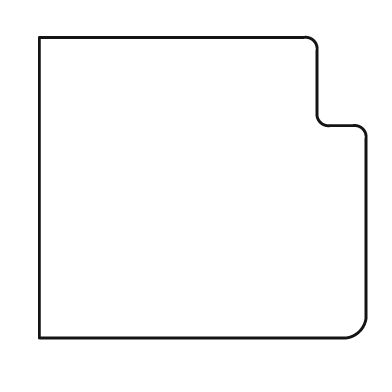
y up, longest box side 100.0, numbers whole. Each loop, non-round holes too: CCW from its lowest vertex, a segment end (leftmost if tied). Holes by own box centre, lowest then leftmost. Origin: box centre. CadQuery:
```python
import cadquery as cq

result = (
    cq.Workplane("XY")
    .moveTo(-50.0, -46.0)
    .lineTo(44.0, -46.0)
    .threePointArc((48.0, -44.0), (50.0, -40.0))
    .lineTo(50.0, 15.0)
    .threePointArc((49.0, 18.0), (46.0, 19.0))
    .lineTo(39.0, 19.0)
    .threePointArc((36.0, 20.0), (35.0, 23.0))
    .lineTo(35.0, 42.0)
    .threePointArc((34.0, 45.0), (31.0, 46.0))
    .lineTo(-50.0, 46.0)
    .close()
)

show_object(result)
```